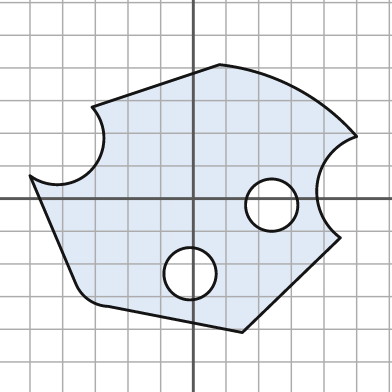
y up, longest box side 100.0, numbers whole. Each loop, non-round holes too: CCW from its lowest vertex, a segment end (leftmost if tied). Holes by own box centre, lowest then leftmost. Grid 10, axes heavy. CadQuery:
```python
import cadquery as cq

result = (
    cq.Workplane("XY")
    .moveTo(15.0, -41.0)
    .lineTo(45.0, -12.0)
    .threePointArc((38.0, 5.0), (50.0, 19.0))
    .threePointArc((31.0, 34.0), (8.0, 41.0))
    .lineTo(-31.0, 28.0)
    .threePointArc((-31.0, 9.0), (-50.0, 7.0))
    .lineTo(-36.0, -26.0)
    .threePointArc((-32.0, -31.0), (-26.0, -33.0))
    .close()
    .moveTo(-1.0, -23.0)
    .circle(8.0)
    .moveTo(24.0, -2.0)
    .circle(8.0)
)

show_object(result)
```